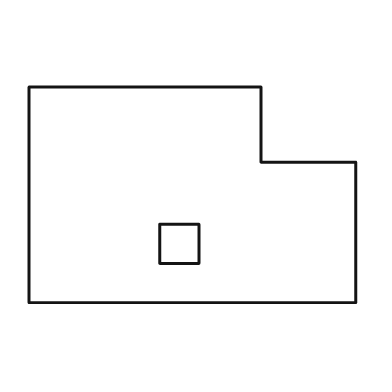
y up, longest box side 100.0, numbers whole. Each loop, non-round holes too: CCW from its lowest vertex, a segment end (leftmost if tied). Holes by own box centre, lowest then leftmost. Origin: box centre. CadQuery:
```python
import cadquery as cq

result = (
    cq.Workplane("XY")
    .moveTo(-50.0, -33.0)
    .lineTo(50.0, -33.0)
    .lineTo(50.0, 10.0)
    .lineTo(21.0, 10.0)
    .lineTo(21.0, 33.0)
    .lineTo(-50.0, 33.0)
    .close()
    .moveTo(-10.0, -21.0)
    .lineTo(2.0, -21.0)
    .lineTo(2.0, -9.0)
    .lineTo(-10.0, -9.0)
    .close()
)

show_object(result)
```